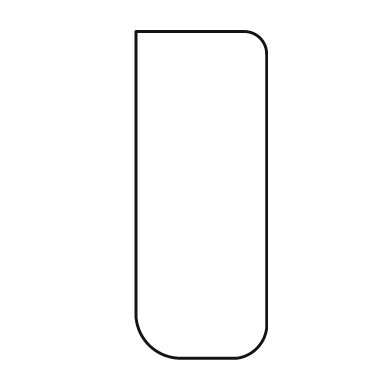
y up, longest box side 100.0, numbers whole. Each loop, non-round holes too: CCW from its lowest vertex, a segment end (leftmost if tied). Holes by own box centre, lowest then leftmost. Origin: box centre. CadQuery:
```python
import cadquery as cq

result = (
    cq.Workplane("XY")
    .moveTo(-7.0, -50.0)
    .lineTo(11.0, -50.0)
    .threePointArc((17.0, -47.0), (20.0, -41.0))
    .lineTo(20.0, 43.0)
    .threePointArc((18.0, 48.0), (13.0, 50.0))
    .lineTo(-20.0, 50.0)
    .lineTo(-20.0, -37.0)
    .threePointArc((-16.0, -46.0), (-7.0, -50.0))
    .close()
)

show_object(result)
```